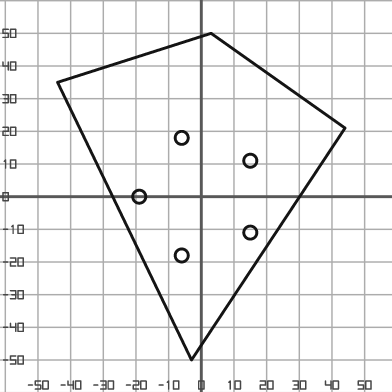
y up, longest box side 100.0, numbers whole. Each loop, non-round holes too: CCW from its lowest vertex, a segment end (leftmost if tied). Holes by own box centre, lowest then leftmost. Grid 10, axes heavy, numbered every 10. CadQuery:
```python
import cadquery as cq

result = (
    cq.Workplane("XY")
    .moveTo(-3.0, -50.0)
    .lineTo(44.0, 21.0)
    .lineTo(3.0, 50.0)
    .lineTo(-44.0, 35.0)
    .close()
    .moveTo(-6.0, -18.0)
    .circle(2.0)
    .moveTo(15.0, -11.0)
    .circle(2.0)
    .moveTo(-19.0, 0.0)
    .circle(2.0)
    .moveTo(15.0, 11.0)
    .circle(2.0)
    .moveTo(-6.0, 18.0)
    .circle(2.0)
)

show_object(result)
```